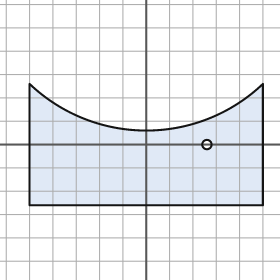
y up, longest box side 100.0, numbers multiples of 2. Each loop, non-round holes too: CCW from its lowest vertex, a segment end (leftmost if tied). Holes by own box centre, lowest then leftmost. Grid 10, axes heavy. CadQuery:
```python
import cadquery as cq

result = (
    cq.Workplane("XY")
    .moveTo(-50.0, -26.0)
    .lineTo(50.0, -26.0)
    .lineTo(50.0, 26.0)
    .threePointArc((0.0, 6.0), (-50.0, 26.0))
    .close()
    .moveTo(26.0, 0.0)
    .circle(2.0)
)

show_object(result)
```